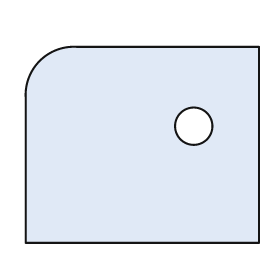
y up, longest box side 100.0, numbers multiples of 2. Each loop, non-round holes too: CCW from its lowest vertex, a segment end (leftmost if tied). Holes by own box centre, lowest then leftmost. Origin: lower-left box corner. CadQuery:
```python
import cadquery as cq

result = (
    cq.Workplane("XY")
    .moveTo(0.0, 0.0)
    .lineTo(100.0, 0.0)
    .lineTo(100.0, 84.0)
    .lineTo(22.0, 84.0)
    .threePointArc((6.0, 78.0), (0.0, 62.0))
    .close()
    .moveTo(72.0, 50.0)
    .circle(8.0)
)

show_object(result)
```